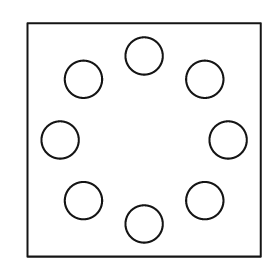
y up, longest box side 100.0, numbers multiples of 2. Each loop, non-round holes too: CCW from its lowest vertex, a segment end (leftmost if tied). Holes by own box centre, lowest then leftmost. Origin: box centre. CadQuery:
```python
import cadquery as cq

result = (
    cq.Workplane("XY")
    .moveTo(-50.0, -50.0)
    .lineTo(50.0, -50.0)
    .lineTo(50.0, 50.0)
    .lineTo(-50.0, 50.0)
    .close()
    .moveTo(0.0, -36.0)
    .circle(8.0)
    .moveTo(-26.0, -26.0)
    .circle(8.0)
    .moveTo(26.0, -26.0)
    .circle(8.0)
    .moveTo(-36.0, 0.0)
    .circle(8.0)
    .moveTo(36.0, 0.0)
    .circle(8.0)
    .moveTo(-26.0, 26.0)
    .circle(8.0)
    .moveTo(26.0, 26.0)
    .circle(8.0)
    .moveTo(0.0, 36.0)
    .circle(8.0)
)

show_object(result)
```